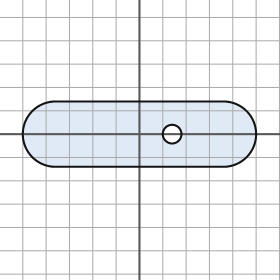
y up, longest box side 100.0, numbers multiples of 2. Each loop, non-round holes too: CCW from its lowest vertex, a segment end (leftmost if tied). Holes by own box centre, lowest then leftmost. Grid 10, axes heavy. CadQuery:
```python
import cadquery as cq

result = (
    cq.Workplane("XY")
    .moveTo(-36.0, -14.0)
    .lineTo(36.0, -14.0)
    .threePointArc((50.0, 0.0), (36.0, 14.0))
    .lineTo(-36.0, 14.0)
    .threePointArc((-50.0, 0.0), (-36.0, -14.0))
    .close()
    .moveTo(14.0, 0.0)
    .circle(4.0)
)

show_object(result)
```